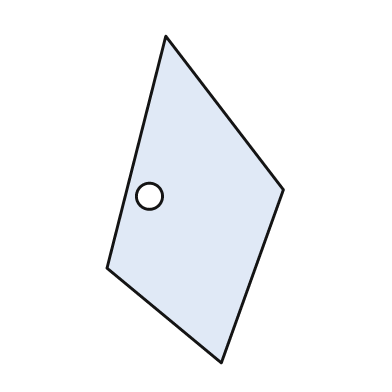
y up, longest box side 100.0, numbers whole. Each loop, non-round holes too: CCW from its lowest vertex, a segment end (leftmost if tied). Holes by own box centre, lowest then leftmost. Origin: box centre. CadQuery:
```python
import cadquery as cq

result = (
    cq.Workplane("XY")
    .moveTo(8.0, -50.0)
    .lineTo(27.0, 3.0)
    .lineTo(-9.0, 50.0)
    .lineTo(-27.0, -21.0)
    .close()
    .moveTo(-14.0, 1.0)
    .circle(4.0)
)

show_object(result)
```